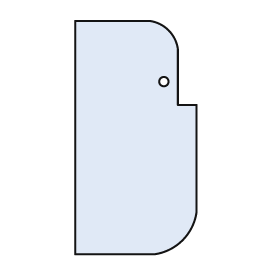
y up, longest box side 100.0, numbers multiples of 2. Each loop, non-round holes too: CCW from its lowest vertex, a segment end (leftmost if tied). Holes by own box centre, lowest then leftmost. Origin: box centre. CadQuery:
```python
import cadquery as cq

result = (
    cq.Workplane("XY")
    .moveTo(-26.0, -50.0)
    .lineTo(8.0, -50.0)
    .threePointArc((20.0, -44.0), (26.0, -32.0))
    .lineTo(26.0, 14.0)
    .lineTo(18.0, 14.0)
    .lineTo(18.0, 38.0)
    .threePointArc((14.0, 46.0), (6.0, 50.0))
    .lineTo(-26.0, 50.0)
    .close()
    .moveTo(12.0, 24.0)
    .circle(2.0)
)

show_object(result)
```